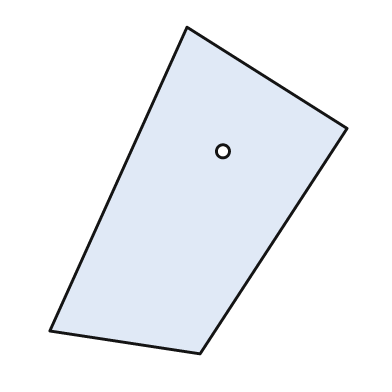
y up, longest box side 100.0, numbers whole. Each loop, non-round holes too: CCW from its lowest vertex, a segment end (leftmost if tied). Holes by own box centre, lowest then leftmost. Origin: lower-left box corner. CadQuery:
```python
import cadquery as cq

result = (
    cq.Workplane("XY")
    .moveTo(46.0, 0.0)
    .lineTo(91.0, 69.0)
    .lineTo(42.0, 100.0)
    .lineTo(0.0, 7.0)
    .close()
    .moveTo(53.0, 62.0)
    .circle(2.0)
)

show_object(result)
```